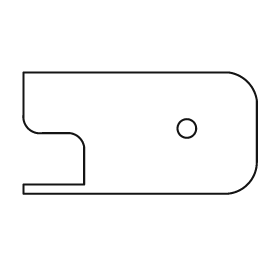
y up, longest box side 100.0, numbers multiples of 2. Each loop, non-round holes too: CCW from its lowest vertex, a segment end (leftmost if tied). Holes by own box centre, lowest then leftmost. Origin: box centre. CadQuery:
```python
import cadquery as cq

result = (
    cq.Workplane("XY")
    .moveTo(-50.0, -26.0)
    .lineTo(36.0, -26.0)
    .threePointArc((46.0, -22.0), (50.0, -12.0))
    .lineTo(50.0, 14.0)
    .threePointArc((46.0, 22.0), (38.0, 26.0))
    .lineTo(-50.0, 26.0)
    .lineTo(-50.0, 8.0)
    .threePointArc((-48.0, 2.0), (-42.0, 0.0))
    .lineTo(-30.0, 0.0)
    .threePointArc((-26.0, -2.0), (-24.0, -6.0))
    .lineTo(-24.0, -22.0)
    .lineTo(-50.0, -22.0)
    .close()
    .moveTo(20.0, 2.0)
    .circle(4.0)
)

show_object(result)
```